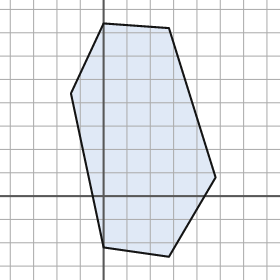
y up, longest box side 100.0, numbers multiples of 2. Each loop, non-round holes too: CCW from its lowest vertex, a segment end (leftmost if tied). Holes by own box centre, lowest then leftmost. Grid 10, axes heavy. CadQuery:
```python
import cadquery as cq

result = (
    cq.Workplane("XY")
    .moveTo(28.0, -26.0)
    .lineTo(48.0, 8.0)
    .lineTo(28.0, 72.0)
    .lineTo(0.0, 74.0)
    .lineTo(-14.0, 44.0)
    .lineTo(0.0, -22.0)
    .close()
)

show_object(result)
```